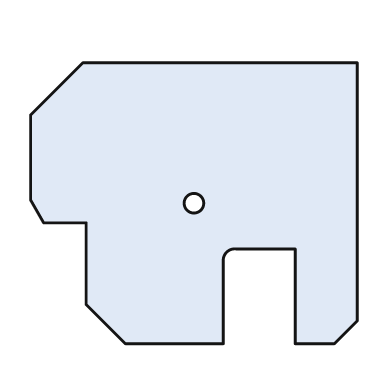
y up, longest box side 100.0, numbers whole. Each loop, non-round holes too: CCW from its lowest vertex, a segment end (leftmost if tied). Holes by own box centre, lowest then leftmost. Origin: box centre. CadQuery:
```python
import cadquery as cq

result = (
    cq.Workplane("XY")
    .moveTo(-21.0, -43.0)
    .lineTo(9.0, -43.0)
    .lineTo(9.0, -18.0)
    .threePointArc((10.0, -15.0), (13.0, -14.0))
    .lineTo(31.0, -14.0)
    .lineTo(31.0, -43.0)
    .lineTo(43.0, -43.0)
    .lineTo(50.0, -36.0)
    .lineTo(50.0, 43.0)
    .lineTo(-34.0, 43.0)
    .lineTo(-50.0, 27.0)
    .lineTo(-50.0, 1.0)
    .lineTo(-46.0, -6.0)
    .lineTo(-33.0, -6.0)
    .lineTo(-33.0, -31.0)
    .close()
    .moveTo(0.0, 0.0)
    .circle(3.0)
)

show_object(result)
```